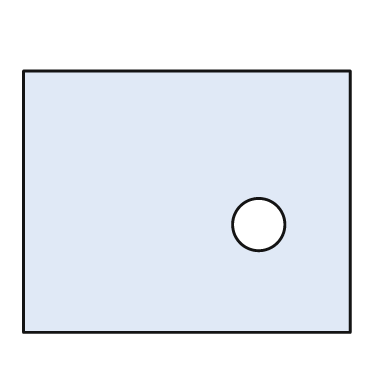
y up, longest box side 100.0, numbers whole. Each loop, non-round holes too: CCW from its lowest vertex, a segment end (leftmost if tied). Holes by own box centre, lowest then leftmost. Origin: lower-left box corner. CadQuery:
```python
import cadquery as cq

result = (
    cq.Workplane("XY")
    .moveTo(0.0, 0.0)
    .lineTo(100.0, 0.0)
    .lineTo(100.0, 80.0)
    .lineTo(0.0, 80.0)
    .close()
    .moveTo(72.0, 33.0)
    .circle(8.0)
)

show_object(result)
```